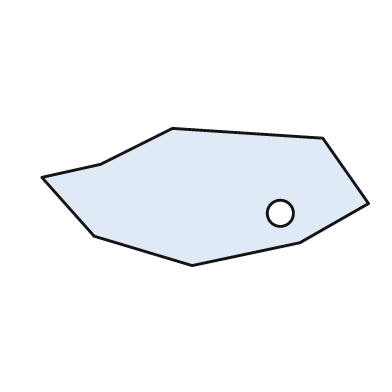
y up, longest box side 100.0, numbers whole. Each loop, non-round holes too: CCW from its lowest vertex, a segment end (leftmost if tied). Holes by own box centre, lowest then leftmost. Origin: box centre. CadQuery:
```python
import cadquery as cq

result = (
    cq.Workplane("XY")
    .moveTo(-4.0, -21.0)
    .lineTo(29.0, -14.0)
    .lineTo(50.0, -2.0)
    .lineTo(36.0, 18.0)
    .lineTo(-10.0, 21.0)
    .lineTo(-32.0, 10.0)
    .lineTo(-50.0, 6.0)
    .lineTo(-34.0, -12.0)
    .close()
    .moveTo(23.0, -5.0)
    .circle(4.0)
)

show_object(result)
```